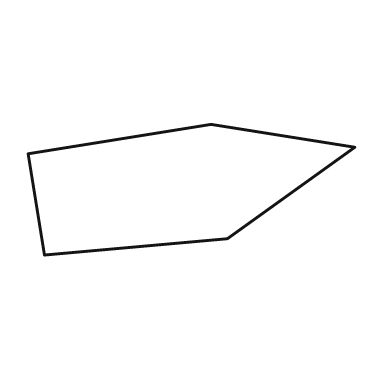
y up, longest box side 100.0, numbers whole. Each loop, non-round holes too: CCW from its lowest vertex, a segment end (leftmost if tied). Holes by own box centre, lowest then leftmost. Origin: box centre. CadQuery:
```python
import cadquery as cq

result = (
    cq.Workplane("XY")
    .moveTo(-45.0, -20.0)
    .lineTo(11.0, -15.0)
    .lineTo(50.0, 13.0)
    .lineTo(6.0, 20.0)
    .lineTo(-50.0, 11.0)
    .close()
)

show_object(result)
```